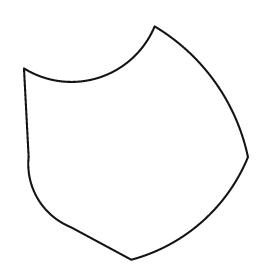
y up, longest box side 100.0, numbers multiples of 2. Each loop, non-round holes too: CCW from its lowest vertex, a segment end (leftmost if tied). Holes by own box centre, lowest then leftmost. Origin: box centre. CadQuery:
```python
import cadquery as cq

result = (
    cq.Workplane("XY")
    .moveTo(-2.0, -50.0)
    .threePointArc((28.0, -34.0), (48.0, -6.0))
    .threePointArc((34.0, 26.0), (8.0, 50.0))
    .threePointArc((-16.0, 28.0), (-48.0, 32.0))
    .lineTo(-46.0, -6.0)
    .threePointArc((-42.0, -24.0), (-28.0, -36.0))
    .close()
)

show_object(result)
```